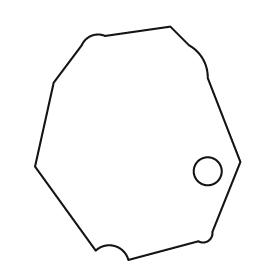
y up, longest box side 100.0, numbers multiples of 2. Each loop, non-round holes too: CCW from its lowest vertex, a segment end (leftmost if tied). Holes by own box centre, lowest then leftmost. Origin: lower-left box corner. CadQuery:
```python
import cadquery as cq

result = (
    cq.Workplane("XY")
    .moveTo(40.0, 0.0)
    .lineTo(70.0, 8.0)
    .threePointArc((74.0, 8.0), (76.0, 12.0))
    .lineTo(88.0, 42.0)
    .lineTo(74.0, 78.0)
    .threePointArc((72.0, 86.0), (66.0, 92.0))
    .lineTo(58.0, 100.0)
    .lineTo(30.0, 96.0)
    .threePointArc((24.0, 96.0), (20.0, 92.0))
    .lineTo(8.0, 76.0)
    .lineTo(0.0, 40.0)
    .lineTo(26.0, 4.0)
    .threePointArc((34.0, 6.0), (40.0, 0.0))
    .close()
    .moveTo(74.0, 38.0)
    .circle(6.0)
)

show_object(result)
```